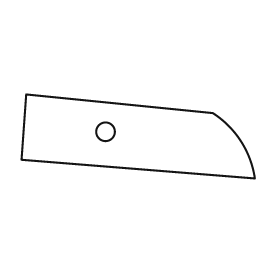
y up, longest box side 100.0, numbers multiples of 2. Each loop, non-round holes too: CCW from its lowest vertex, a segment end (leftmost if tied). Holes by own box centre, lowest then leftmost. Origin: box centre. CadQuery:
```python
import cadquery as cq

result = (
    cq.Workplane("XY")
    .moveTo(50.0, -18.0)
    .threePointArc((44.0, -2.0), (32.0, 10.0))
    .lineTo(-48.0, 18.0)
    .lineTo(-50.0, -10.0)
    .close()
    .moveTo(-14.0, 2.0)
    .circle(4.0)
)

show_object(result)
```